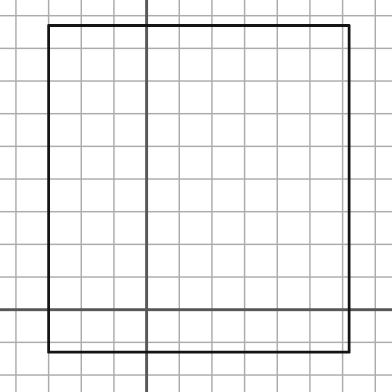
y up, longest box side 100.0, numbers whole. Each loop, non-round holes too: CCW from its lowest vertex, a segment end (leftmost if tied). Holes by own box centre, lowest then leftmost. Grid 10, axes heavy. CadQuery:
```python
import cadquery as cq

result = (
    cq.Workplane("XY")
    .moveTo(-30.0, -13.0)
    .lineTo(62.0, -13.0)
    .lineTo(62.0, 87.0)
    .lineTo(-30.0, 87.0)
    .close()
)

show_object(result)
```